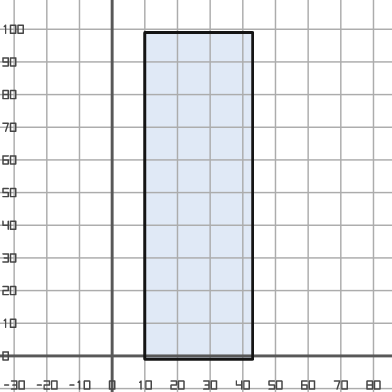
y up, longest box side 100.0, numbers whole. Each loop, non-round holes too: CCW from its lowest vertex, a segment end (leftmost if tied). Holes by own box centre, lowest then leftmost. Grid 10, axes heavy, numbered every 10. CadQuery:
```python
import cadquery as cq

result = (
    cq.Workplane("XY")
    .moveTo(10.0, -1.0)
    .lineTo(43.0, -1.0)
    .lineTo(43.0, 99.0)
    .lineTo(10.0, 99.0)
    .close()
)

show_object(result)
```